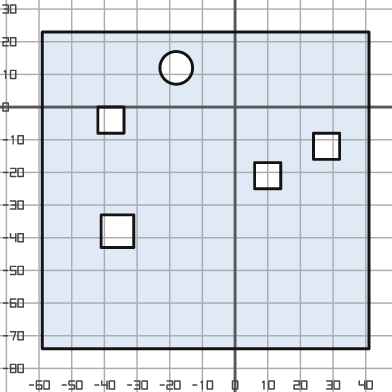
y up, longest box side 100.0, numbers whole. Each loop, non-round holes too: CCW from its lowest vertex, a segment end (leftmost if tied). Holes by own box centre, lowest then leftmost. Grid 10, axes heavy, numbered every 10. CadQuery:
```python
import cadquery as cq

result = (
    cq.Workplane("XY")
    .moveTo(-59.0, -74.0)
    .lineTo(41.0, -74.0)
    .lineTo(41.0, 23.0)
    .lineTo(-59.0, 23.0)
    .close()
    .moveTo(-41.0, -43.0)
    .lineTo(-31.0, -43.0)
    .lineTo(-31.0, -33.0)
    .lineTo(-41.0, -33.0)
    .close()
    .moveTo(6.0, -25.0)
    .lineTo(14.0, -25.0)
    .lineTo(14.0, -17.0)
    .lineTo(6.0, -17.0)
    .close()
    .moveTo(24.0, -16.0)
    .lineTo(32.0, -16.0)
    .lineTo(32.0, -8.0)
    .lineTo(24.0, -8.0)
    .close()
    .moveTo(-42.0, -8.0)
    .lineTo(-34.0, -8.0)
    .lineTo(-34.0, 0.0)
    .lineTo(-42.0, 0.0)
    .close()
    .moveTo(-18.0, 12.0)
    .circle(5.0)
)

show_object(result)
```